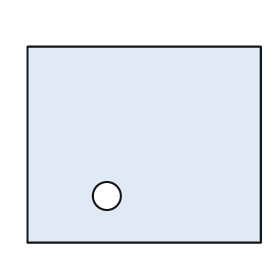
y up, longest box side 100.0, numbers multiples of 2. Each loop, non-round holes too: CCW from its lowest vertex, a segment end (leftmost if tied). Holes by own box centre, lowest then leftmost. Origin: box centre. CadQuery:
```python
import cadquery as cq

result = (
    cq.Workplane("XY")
    .moveTo(-50.0, -42.0)
    .lineTo(50.0, -42.0)
    .lineTo(50.0, 42.0)
    .lineTo(-50.0, 42.0)
    .close()
    .moveTo(-16.0, -22.0)
    .circle(6.0)
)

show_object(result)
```